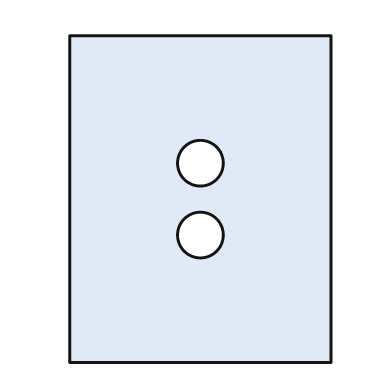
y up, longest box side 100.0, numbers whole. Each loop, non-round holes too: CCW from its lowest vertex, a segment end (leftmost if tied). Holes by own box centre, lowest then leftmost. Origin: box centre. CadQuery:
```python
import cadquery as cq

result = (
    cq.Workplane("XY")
    .moveTo(-40.0, -50.0)
    .lineTo(40.0, -50.0)
    .lineTo(40.0, 50.0)
    .lineTo(-40.0, 50.0)
    .close()
    .moveTo(0.0, -11.0)
    .circle(7.0)
    .moveTo(0.0, 11.0)
    .circle(7.0)
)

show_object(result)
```